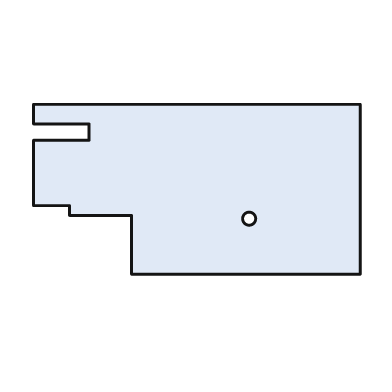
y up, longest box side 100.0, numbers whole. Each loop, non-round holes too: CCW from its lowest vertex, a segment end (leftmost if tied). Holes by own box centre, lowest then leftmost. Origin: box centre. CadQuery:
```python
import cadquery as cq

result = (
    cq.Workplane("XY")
    .moveTo(-20.0, -26.0)
    .lineTo(50.0, -26.0)
    .lineTo(50.0, 26.0)
    .lineTo(-50.0, 26.0)
    .lineTo(-50.0, 20.0)
    .lineTo(-33.0, 20.0)
    .lineTo(-33.0, 15.0)
    .lineTo(-50.0, 15.0)
    .lineTo(-50.0, -5.0)
    .lineTo(-39.0, -5.0)
    .lineTo(-39.0, -8.0)
    .lineTo(-20.0, -8.0)
    .close()
    .moveTo(16.0, -9.0)
    .circle(2.0)
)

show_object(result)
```